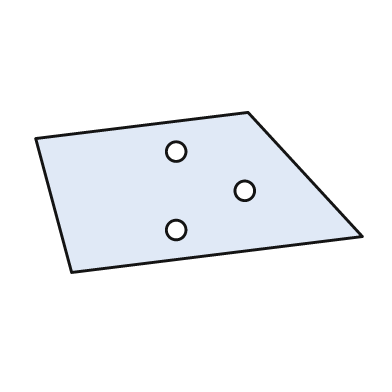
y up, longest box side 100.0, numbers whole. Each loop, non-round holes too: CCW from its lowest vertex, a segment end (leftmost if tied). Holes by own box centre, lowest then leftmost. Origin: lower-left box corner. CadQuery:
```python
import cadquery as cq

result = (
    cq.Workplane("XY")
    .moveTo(11.0, 0.0)
    .lineTo(100.0, 11.0)
    .lineTo(65.0, 49.0)
    .lineTo(0.0, 41.0)
    .close()
    .moveTo(43.0, 13.0)
    .circle(3.0)
    .moveTo(64.0, 25.0)
    .circle(3.0)
    .moveTo(43.0, 37.0)
    .circle(3.0)
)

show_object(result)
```